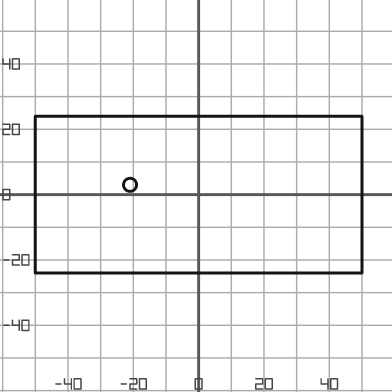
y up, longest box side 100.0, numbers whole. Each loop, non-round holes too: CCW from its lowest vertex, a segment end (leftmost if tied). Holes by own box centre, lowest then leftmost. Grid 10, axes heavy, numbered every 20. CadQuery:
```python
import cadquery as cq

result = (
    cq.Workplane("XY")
    .moveTo(-50.0, -24.0)
    .lineTo(50.0, -24.0)
    .lineTo(50.0, 24.0)
    .lineTo(-50.0, 24.0)
    .close()
    .moveTo(-21.0, 3.0)
    .circle(2.0)
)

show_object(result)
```